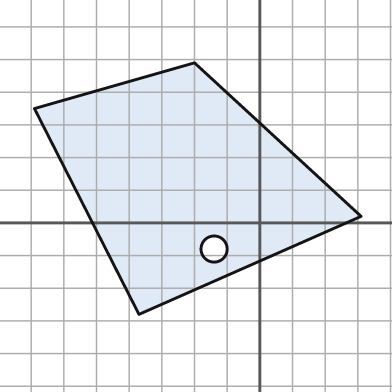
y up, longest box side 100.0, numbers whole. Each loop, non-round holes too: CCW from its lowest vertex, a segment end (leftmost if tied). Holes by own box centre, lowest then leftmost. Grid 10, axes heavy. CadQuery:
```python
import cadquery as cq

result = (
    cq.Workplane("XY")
    .moveTo(-37.0, -28.0)
    .lineTo(31.0, 2.0)
    .lineTo(-20.0, 49.0)
    .lineTo(-69.0, 35.0)
    .close()
    .moveTo(-14.0, -8.0)
    .circle(4.0)
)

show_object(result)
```